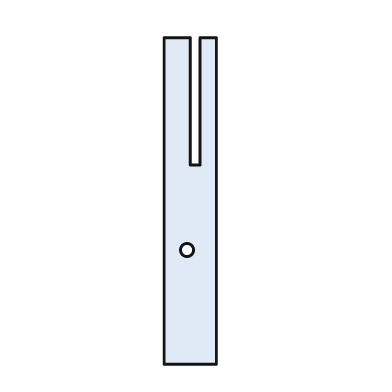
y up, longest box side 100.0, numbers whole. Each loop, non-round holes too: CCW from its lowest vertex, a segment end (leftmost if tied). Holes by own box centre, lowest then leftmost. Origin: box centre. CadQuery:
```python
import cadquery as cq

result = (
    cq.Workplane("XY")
    .moveTo(-8.0, -50.0)
    .lineTo(8.0, -50.0)
    .lineTo(8.0, 50.0)
    .lineTo(3.0, 50.0)
    .lineTo(3.0, 11.0)
    .lineTo(0.0, 11.0)
    .lineTo(0.0, 50.0)
    .lineTo(-8.0, 50.0)
    .close()
    .moveTo(-1.0, -15.0)
    .circle(2.0)
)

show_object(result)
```